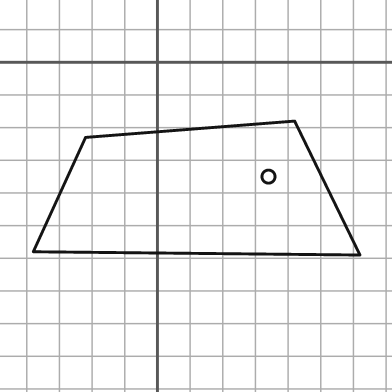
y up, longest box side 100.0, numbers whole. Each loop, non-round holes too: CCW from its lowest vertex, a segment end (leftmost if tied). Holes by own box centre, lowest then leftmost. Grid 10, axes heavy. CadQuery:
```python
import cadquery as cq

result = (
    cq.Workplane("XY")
    .moveTo(62.0, -59.0)
    .lineTo(42.0, -18.0)
    .lineTo(-22.0, -23.0)
    .lineTo(-38.0, -58.0)
    .close()
    .moveTo(34.0, -35.0)
    .circle(2.0)
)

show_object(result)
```